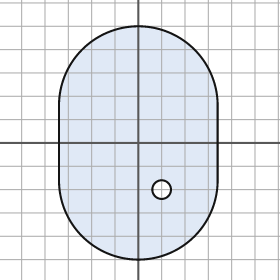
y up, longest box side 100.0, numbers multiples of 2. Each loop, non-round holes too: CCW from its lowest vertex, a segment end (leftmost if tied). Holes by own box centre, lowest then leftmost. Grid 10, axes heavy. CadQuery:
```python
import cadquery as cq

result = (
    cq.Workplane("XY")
    .moveTo(-34.0, -16.0)
    .threePointArc((0.0, -50.0), (34.0, -16.0))
    .lineTo(34.0, 16.0)
    .threePointArc((0.0, 50.0), (-34.0, 16.0))
    .close()
    .moveTo(10.0, -20.0)
    .circle(4.0)
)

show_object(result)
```